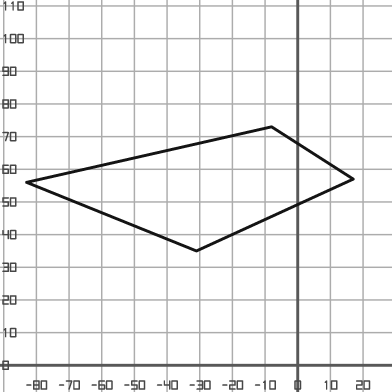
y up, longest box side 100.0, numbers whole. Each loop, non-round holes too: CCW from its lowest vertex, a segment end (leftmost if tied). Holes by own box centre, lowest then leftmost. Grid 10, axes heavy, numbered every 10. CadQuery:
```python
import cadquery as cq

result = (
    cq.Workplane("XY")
    .moveTo(-31.0, 35.0)
    .lineTo(17.0, 57.0)
    .lineTo(-8.0, 73.0)
    .lineTo(-83.0, 56.0)
    .close()
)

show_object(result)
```